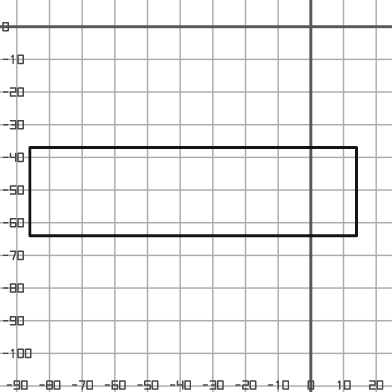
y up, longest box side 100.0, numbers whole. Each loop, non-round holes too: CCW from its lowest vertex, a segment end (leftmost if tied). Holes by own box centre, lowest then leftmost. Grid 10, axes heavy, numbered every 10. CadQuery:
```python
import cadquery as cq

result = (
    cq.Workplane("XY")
    .moveTo(-86.0, -64.0)
    .lineTo(14.0, -64.0)
    .lineTo(14.0, -37.0)
    .lineTo(-86.0, -37.0)
    .close()
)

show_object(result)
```